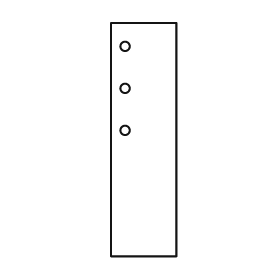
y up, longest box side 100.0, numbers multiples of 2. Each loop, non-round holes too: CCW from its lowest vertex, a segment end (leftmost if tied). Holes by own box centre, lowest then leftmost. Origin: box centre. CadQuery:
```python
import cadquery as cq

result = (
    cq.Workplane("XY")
    .moveTo(-14.0, -50.0)
    .lineTo(14.0, -50.0)
    .lineTo(14.0, 50.0)
    .lineTo(-14.0, 50.0)
    .close()
    .moveTo(-8.0, 4.0)
    .circle(2.0)
    .moveTo(-8.0, 22.0)
    .circle(2.0)
    .moveTo(-8.0, 40.0)
    .circle(2.0)
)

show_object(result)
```